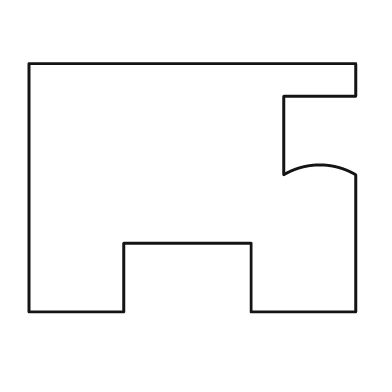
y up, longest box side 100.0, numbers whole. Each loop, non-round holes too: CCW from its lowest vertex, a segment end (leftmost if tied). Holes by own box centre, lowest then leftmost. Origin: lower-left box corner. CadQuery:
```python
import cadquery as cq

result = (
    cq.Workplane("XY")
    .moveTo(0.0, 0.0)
    .lineTo(29.0, 0.0)
    .lineTo(29.0, 21.0)
    .lineTo(68.0, 21.0)
    .lineTo(68.0, 0.0)
    .lineTo(100.0, 0.0)
    .lineTo(100.0, 42.0)
    .threePointArc((89.0, 45.0), (78.0, 42.0))
    .lineTo(78.0, 66.0)
    .lineTo(100.0, 66.0)
    .lineTo(100.0, 76.0)
    .lineTo(0.0, 76.0)
    .close()
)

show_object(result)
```